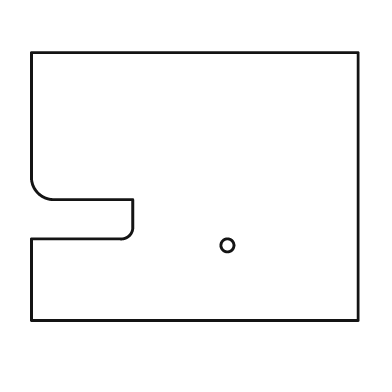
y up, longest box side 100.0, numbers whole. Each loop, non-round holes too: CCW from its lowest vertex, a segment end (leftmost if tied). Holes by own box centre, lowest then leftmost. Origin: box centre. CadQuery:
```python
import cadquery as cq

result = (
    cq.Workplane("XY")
    .moveTo(-50.0, -41.0)
    .lineTo(50.0, -41.0)
    .lineTo(50.0, 41.0)
    .lineTo(-50.0, 41.0)
    .lineTo(-50.0, 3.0)
    .threePointArc((-48.0, -2.0), (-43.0, -4.0))
    .lineTo(-19.0, -4.0)
    .lineTo(-19.0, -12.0)
    .threePointArc((-20.0, -15.0), (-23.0, -16.0))
    .lineTo(-50.0, -16.0)
    .close()
    .moveTo(10.0, -18.0)
    .circle(2.0)
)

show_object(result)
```